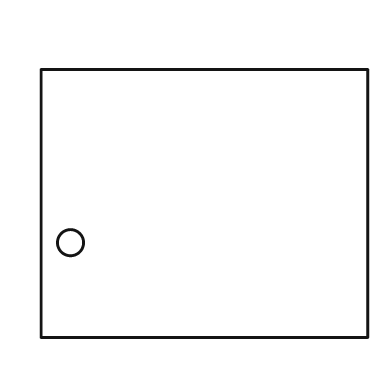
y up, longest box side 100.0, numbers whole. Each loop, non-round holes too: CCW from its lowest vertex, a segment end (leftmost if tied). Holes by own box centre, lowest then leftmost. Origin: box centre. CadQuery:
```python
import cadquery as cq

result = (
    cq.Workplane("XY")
    .moveTo(-50.0, -41.0)
    .lineTo(50.0, -41.0)
    .lineTo(50.0, 41.0)
    .lineTo(-50.0, 41.0)
    .close()
    .moveTo(-41.0, -12.0)
    .circle(4.0)
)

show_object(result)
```